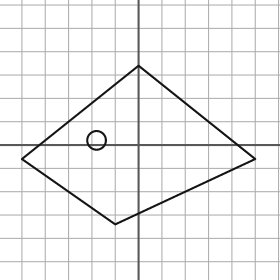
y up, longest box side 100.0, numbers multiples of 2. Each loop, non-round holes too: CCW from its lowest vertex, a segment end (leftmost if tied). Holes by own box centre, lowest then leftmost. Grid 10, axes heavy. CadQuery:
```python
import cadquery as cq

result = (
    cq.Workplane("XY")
    .moveTo(-10.0, -34.0)
    .lineTo(50.0, -6.0)
    .lineTo(0.0, 34.0)
    .lineTo(-50.0, -6.0)
    .close()
    .moveTo(-18.0, 2.0)
    .circle(4.0)
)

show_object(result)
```